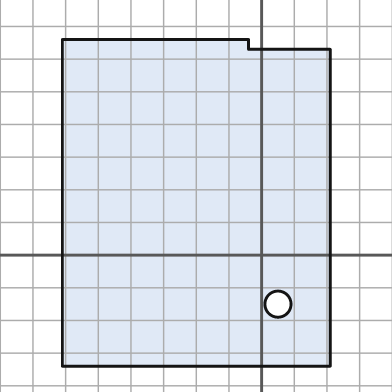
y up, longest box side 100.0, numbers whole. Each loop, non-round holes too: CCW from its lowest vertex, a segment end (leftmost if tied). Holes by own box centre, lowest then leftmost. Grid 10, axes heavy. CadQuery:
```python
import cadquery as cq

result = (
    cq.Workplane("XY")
    .moveTo(-61.0, -34.0)
    .lineTo(21.0, -34.0)
    .lineTo(21.0, 63.0)
    .lineTo(-4.0, 63.0)
    .lineTo(-4.0, 66.0)
    .lineTo(-61.0, 66.0)
    .close()
    .moveTo(5.0, -15.0)
    .circle(4.0)
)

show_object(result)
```